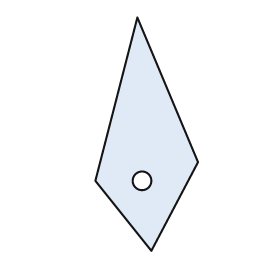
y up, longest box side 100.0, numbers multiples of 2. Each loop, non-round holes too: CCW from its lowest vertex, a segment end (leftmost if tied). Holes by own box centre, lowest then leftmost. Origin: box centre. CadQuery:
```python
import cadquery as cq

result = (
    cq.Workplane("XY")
    .moveTo(2.0, -50.0)
    .lineTo(22.0, -12.0)
    .lineTo(-4.0, 50.0)
    .lineTo(-22.0, -20.0)
    .close()
    .moveTo(-2.0, -20.0)
    .circle(4.0)
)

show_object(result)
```